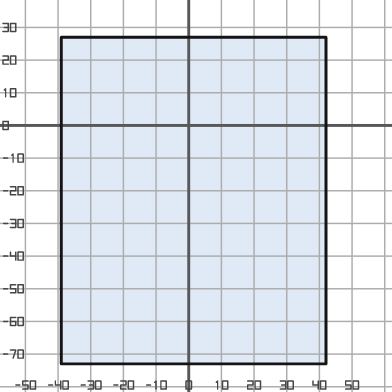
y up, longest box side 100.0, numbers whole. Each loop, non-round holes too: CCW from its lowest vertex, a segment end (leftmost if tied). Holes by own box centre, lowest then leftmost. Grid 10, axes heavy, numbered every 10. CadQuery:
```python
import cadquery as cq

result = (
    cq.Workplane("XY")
    .moveTo(-39.0, -73.0)
    .lineTo(42.0, -73.0)
    .lineTo(42.0, 27.0)
    .lineTo(-39.0, 27.0)
    .close()
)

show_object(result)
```